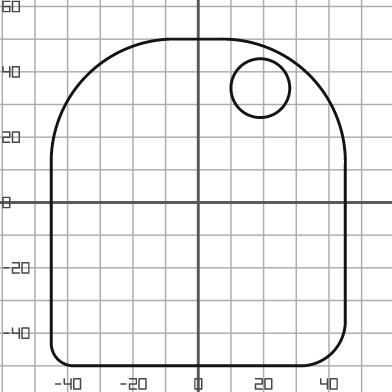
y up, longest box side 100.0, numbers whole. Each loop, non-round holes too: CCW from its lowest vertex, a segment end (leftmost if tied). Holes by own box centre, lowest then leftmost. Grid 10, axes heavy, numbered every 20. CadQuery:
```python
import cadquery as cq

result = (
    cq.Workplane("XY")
    .moveTo(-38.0, -50.0)
    .lineTo(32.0, -50.0)
    .threePointArc((41.0, -46.0), (45.0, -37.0))
    .lineTo(45.0, 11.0)
    .threePointArc((34.0, 39.0), (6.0, 50.0))
    .lineTo(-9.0, 50.0)
    .threePointArc((-34.0, 39.0), (-45.0, 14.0))
    .lineTo(-45.0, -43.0)
    .threePointArc((-43.0, -48.0), (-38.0, -50.0))
    .close()
    .moveTo(19.0, 35.0)
    .circle(9.0)
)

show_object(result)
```